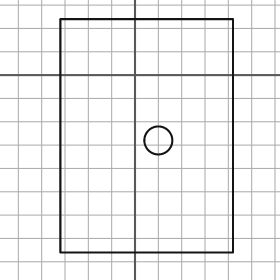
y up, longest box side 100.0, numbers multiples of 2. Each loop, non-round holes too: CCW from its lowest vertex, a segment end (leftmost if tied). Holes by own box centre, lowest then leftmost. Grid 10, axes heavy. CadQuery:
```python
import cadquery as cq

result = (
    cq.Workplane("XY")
    .moveTo(-32.0, -76.0)
    .lineTo(42.0, -76.0)
    .lineTo(42.0, 24.0)
    .lineTo(-32.0, 24.0)
    .close()
    .moveTo(10.0, -28.0)
    .circle(6.0)
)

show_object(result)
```